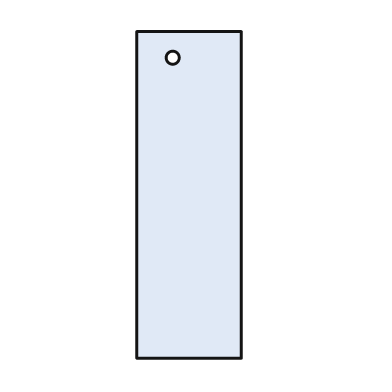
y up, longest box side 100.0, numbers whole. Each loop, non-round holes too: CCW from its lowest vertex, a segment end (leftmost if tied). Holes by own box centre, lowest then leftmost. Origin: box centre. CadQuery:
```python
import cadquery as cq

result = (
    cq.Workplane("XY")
    .moveTo(-16.0, -50.0)
    .lineTo(16.0, -50.0)
    .lineTo(16.0, 50.0)
    .lineTo(-16.0, 50.0)
    .close()
    .moveTo(-5.0, 42.0)
    .circle(2.0)
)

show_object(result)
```